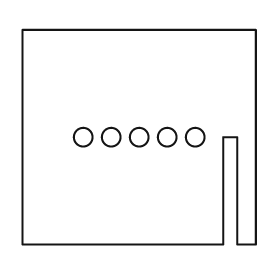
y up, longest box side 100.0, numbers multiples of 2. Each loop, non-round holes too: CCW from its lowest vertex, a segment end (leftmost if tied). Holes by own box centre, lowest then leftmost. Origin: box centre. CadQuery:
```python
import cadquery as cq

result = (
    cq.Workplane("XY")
    .moveTo(-50.0, -46.0)
    .lineTo(36.0, -46.0)
    .lineTo(36.0, 0.0)
    .lineTo(42.0, 0.0)
    .lineTo(42.0, -46.0)
    .lineTo(50.0, -46.0)
    .lineTo(50.0, 46.0)
    .lineTo(-50.0, 46.0)
    .close()
    .moveTo(-24.0, 0.0)
    .circle(4.0)
    .moveTo(-12.0, 0.0)
    .circle(4.0)
    .moveTo(0.0, 0.0)
    .circle(4.0)
    .moveTo(12.0, 0.0)
    .circle(4.0)
    .moveTo(24.0, 0.0)
    .circle(4.0)
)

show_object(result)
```